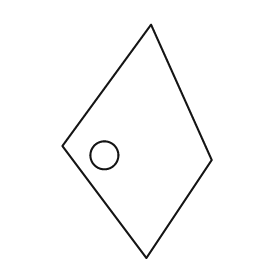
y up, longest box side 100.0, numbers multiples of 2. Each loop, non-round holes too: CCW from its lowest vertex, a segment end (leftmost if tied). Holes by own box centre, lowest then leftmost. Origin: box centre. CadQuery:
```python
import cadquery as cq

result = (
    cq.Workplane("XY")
    .moveTo(4.0, -50.0)
    .lineTo(32.0, -8.0)
    .lineTo(6.0, 50.0)
    .lineTo(-32.0, -2.0)
    .close()
    .moveTo(-14.0, -6.0)
    .circle(6.0)
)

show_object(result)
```